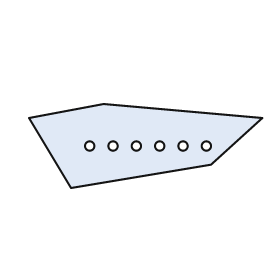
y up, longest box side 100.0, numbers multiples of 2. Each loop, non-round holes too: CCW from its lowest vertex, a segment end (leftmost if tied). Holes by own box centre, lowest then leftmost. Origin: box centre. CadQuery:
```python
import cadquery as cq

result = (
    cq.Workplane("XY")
    .moveTo(-32.0, -18.0)
    .lineTo(28.0, -8.0)
    .lineTo(50.0, 12.0)
    .lineTo(-18.0, 18.0)
    .lineTo(-50.0, 12.0)
    .close()
    .moveTo(-24.0, 0.0)
    .circle(2.0)
    .moveTo(-14.0, 0.0)
    .circle(2.0)
    .moveTo(-4.0, 0.0)
    .circle(2.0)
    .moveTo(6.0, 0.0)
    .circle(2.0)
    .moveTo(16.0, 0.0)
    .circle(2.0)
    .moveTo(26.0, 0.0)
    .circle(2.0)
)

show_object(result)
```